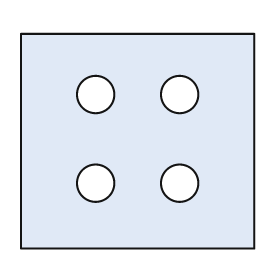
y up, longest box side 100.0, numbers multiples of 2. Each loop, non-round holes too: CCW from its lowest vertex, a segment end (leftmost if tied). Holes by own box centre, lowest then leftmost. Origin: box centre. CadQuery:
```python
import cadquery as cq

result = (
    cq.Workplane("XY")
    .moveTo(-50.0, -46.0)
    .lineTo(50.0, -46.0)
    .lineTo(50.0, 46.0)
    .lineTo(-50.0, 46.0)
    .close()
    .moveTo(-18.0, -18.0)
    .circle(8.0)
    .moveTo(18.0, -18.0)
    .circle(8.0)
    .moveTo(-18.0, 20.0)
    .circle(8.0)
    .moveTo(18.0, 20.0)
    .circle(8.0)
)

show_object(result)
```